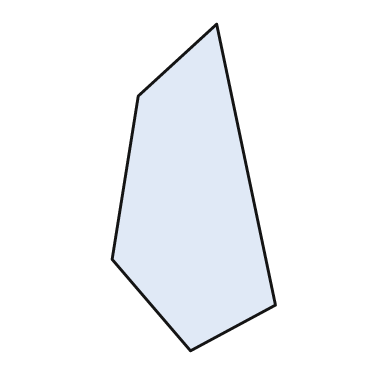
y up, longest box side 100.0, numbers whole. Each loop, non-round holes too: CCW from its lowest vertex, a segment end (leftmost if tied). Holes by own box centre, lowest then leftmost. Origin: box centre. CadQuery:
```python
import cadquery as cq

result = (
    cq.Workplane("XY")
    .moveTo(-1.0, -50.0)
    .lineTo(25.0, -36.0)
    .lineTo(7.0, 50.0)
    .lineTo(-17.0, 28.0)
    .lineTo(-25.0, -22.0)
    .close()
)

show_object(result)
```